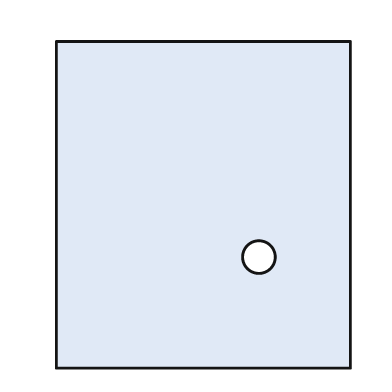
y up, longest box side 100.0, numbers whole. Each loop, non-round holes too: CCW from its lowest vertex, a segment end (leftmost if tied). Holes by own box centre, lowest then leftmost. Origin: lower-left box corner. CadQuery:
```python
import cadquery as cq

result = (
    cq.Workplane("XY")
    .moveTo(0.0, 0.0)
    .lineTo(90.0, 0.0)
    .lineTo(90.0, 100.0)
    .lineTo(0.0, 100.0)
    .close()
    .moveTo(62.0, 34.0)
    .circle(5.0)
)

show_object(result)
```